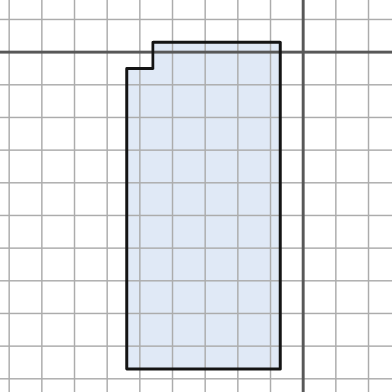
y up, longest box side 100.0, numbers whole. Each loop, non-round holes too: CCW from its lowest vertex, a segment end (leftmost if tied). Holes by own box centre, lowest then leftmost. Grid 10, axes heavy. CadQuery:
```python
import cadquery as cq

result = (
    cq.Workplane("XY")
    .moveTo(-54.0, -97.0)
    .lineTo(-7.0, -97.0)
    .lineTo(-7.0, 3.0)
    .lineTo(-46.0, 3.0)
    .lineTo(-46.0, -5.0)
    .lineTo(-54.0, -5.0)
    .close()
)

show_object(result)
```